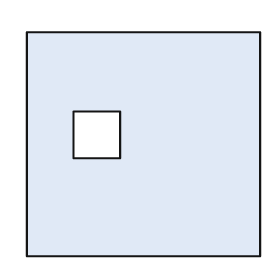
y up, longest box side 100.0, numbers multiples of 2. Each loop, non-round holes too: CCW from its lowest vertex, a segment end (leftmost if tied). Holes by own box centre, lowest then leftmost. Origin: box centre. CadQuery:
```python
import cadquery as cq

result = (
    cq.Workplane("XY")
    .moveTo(-50.0, -48.0)
    .lineTo(50.0, -48.0)
    .lineTo(50.0, 48.0)
    .lineTo(-50.0, 48.0)
    .close()
    .moveTo(-30.0, -6.0)
    .lineTo(-10.0, -6.0)
    .lineTo(-10.0, 14.0)
    .lineTo(-30.0, 14.0)
    .close()
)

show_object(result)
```